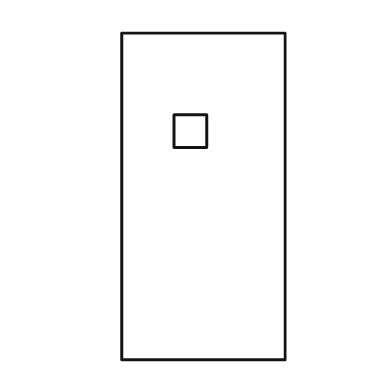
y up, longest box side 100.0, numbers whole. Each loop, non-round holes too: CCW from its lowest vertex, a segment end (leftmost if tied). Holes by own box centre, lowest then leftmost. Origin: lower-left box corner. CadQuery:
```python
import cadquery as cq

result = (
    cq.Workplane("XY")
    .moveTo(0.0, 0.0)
    .lineTo(50.0, 0.0)
    .lineTo(50.0, 100.0)
    .lineTo(0.0, 100.0)
    .close()
    .moveTo(16.0, 65.0)
    .lineTo(26.0, 65.0)
    .lineTo(26.0, 75.0)
    .lineTo(16.0, 75.0)
    .close()
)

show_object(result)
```